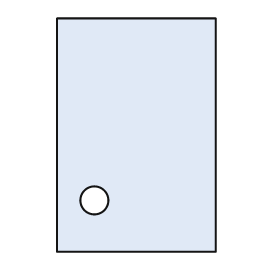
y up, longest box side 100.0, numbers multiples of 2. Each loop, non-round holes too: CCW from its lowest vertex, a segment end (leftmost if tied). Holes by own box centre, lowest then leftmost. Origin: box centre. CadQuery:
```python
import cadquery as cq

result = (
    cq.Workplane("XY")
    .moveTo(-34.0, -50.0)
    .lineTo(34.0, -50.0)
    .lineTo(34.0, 50.0)
    .lineTo(-34.0, 50.0)
    .close()
    .moveTo(-18.0, -28.0)
    .circle(6.0)
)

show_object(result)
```